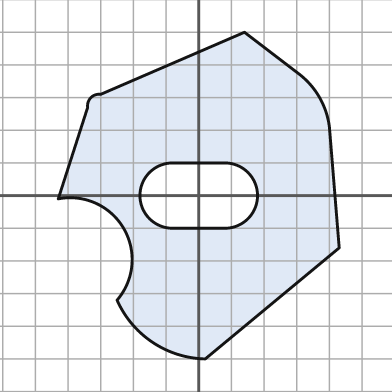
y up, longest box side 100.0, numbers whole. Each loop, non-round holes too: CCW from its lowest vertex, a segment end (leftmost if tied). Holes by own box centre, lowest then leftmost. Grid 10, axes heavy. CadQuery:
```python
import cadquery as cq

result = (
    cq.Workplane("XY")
    .moveTo(2.0, -50.0)
    .lineTo(43.0, -16.0)
    .lineTo(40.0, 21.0)
    .threePointArc((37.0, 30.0), (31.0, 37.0))
    .lineTo(14.0, 50.0)
    .lineTo(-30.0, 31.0)
    .threePointArc((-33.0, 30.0), (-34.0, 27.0))
    .lineTo(-43.0, -1.0)
    .threePointArc((-23.0, -10.0), (-25.0, -32.0))
    .threePointArc((-14.0, -45.0), (2.0, -50.0))
    .close()
    .moveTo(-8.0, -10.0)
    .lineTo(8.0, -10.0)
    .threePointArc((18.0, 0.0), (8.0, 10.0))
    .lineTo(-8.0, 10.0)
    .threePointArc((-18.0, 0.0), (-8.0, -10.0))
    .close()
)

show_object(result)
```